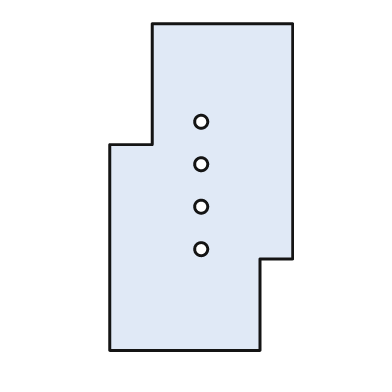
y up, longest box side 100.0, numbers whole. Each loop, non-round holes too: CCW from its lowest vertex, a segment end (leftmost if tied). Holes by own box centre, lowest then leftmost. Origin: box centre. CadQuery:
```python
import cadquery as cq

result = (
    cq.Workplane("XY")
    .moveTo(-28.0, -50.0)
    .lineTo(18.0, -50.0)
    .lineTo(18.0, -22.0)
    .lineTo(28.0, -22.0)
    .lineTo(28.0, 50.0)
    .lineTo(-15.0, 50.0)
    .lineTo(-15.0, 13.0)
    .lineTo(-28.0, 13.0)
    .close()
    .moveTo(0.0, -19.0)
    .circle(2.0)
    .moveTo(0.0, -6.0)
    .circle(2.0)
    .moveTo(0.0, 7.0)
    .circle(2.0)
    .moveTo(0.0, 20.0)
    .circle(2.0)
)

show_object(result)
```